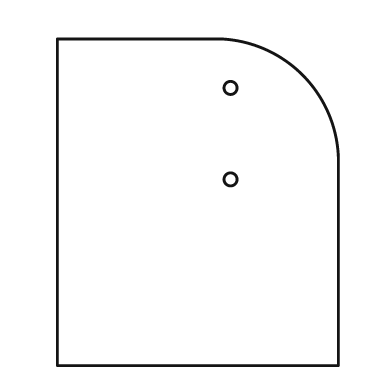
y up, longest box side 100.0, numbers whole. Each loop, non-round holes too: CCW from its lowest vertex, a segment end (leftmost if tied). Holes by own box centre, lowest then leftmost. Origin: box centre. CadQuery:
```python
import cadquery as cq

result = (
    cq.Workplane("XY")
    .moveTo(-43.0, -50.0)
    .lineTo(43.0, -50.0)
    .lineTo(43.0, 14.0)
    .threePointArc((32.0, 39.0), (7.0, 50.0))
    .lineTo(-43.0, 50.0)
    .close()
    .moveTo(10.0, 7.0)
    .circle(2.0)
    .moveTo(10.0, 35.0)
    .circle(2.0)
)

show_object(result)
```